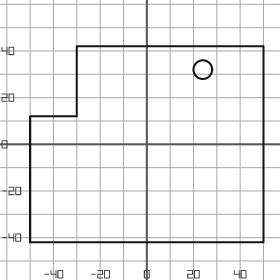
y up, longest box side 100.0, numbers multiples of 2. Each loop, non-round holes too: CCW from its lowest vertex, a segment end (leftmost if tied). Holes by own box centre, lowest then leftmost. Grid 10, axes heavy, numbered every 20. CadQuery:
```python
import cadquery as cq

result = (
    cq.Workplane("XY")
    .moveTo(-50.0, -42.0)
    .lineTo(50.0, -42.0)
    .lineTo(50.0, 42.0)
    .lineTo(-30.0, 42.0)
    .lineTo(-30.0, 12.0)
    .lineTo(-50.0, 12.0)
    .close()
    .moveTo(24.0, 32.0)
    .circle(4.0)
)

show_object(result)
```